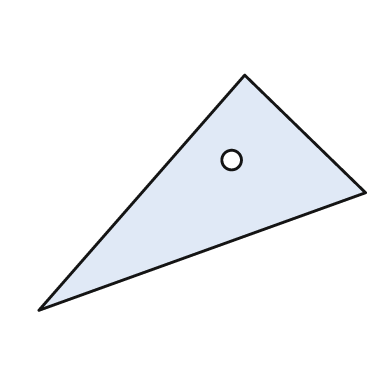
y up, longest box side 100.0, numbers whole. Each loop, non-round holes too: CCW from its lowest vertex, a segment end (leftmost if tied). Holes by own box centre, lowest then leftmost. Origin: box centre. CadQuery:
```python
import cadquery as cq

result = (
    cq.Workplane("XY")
    .moveTo(-50.0, -36.0)
    .lineTo(50.0, 0.0)
    .lineTo(13.0, 36.0)
    .close()
    .moveTo(9.0, 10.0)
    .circle(3.0)
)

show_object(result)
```